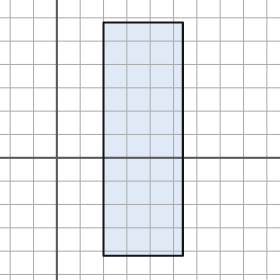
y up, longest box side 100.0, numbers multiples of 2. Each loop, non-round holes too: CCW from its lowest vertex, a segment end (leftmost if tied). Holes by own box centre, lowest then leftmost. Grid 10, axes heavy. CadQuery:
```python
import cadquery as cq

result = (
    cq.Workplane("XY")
    .moveTo(20.0, -42.0)
    .lineTo(54.0, -42.0)
    .lineTo(54.0, 58.0)
    .lineTo(20.0, 58.0)
    .close()
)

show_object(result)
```